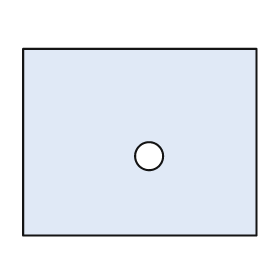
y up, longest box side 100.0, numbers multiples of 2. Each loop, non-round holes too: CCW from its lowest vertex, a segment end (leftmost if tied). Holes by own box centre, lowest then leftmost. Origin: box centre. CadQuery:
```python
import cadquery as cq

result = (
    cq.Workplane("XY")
    .moveTo(-50.0, -40.0)
    .lineTo(50.0, -40.0)
    .lineTo(50.0, 40.0)
    .lineTo(-50.0, 40.0)
    .close()
    .moveTo(4.0, -6.0)
    .circle(6.0)
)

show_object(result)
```